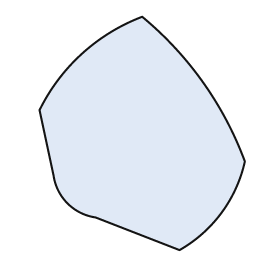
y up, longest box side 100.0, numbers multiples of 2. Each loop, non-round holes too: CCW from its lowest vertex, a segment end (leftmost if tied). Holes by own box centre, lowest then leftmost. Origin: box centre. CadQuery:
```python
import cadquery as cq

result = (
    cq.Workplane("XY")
    .moveTo(16.0, -50.0)
    .threePointArc((34.0, -34.0), (44.0, -12.0))
    .threePointArc((26.0, 22.0), (0.0, 50.0))
    .threePointArc((-26.0, 34.0), (-44.0, 10.0))
    .lineTo(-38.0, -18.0)
    .threePointArc((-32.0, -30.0), (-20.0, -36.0))
    .close()
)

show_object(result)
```